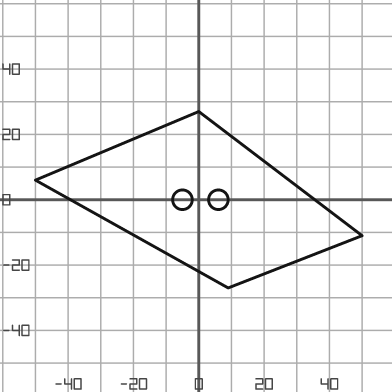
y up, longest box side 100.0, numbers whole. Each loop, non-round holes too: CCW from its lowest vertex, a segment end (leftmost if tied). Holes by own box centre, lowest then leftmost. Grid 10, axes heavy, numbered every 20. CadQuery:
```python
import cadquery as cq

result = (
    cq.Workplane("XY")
    .moveTo(9.0, -27.0)
    .lineTo(50.0, -11.0)
    .lineTo(0.0, 27.0)
    .lineTo(-50.0, 6.0)
    .close()
    .moveTo(-5.0, 0.0)
    .circle(3.0)
    .moveTo(6.0, 0.0)
    .circle(3.0)
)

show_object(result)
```